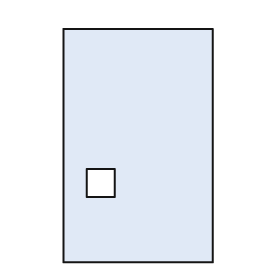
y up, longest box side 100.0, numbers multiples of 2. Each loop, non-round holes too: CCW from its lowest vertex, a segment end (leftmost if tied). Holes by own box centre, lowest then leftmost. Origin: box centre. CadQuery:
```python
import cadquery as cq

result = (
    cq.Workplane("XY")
    .moveTo(-32.0, -50.0)
    .lineTo(32.0, -50.0)
    .lineTo(32.0, 50.0)
    .lineTo(-32.0, 50.0)
    .close()
    .moveTo(-22.0, -22.0)
    .lineTo(-10.0, -22.0)
    .lineTo(-10.0, -10.0)
    .lineTo(-22.0, -10.0)
    .close()
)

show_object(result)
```